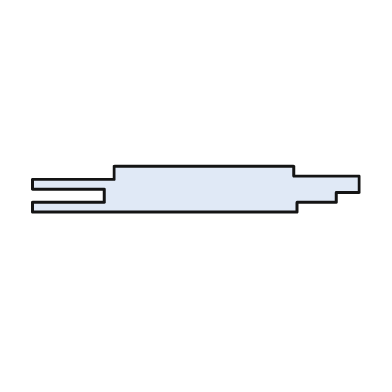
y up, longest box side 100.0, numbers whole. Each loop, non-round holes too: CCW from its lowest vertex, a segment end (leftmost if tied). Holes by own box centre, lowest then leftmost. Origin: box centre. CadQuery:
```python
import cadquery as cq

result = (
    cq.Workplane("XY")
    .moveTo(-50.0, -7.0)
    .lineTo(31.0, -7.0)
    .lineTo(31.0, -4.0)
    .lineTo(43.0, -4.0)
    .lineTo(43.0, -1.0)
    .lineTo(50.0, -1.0)
    .lineTo(50.0, 4.0)
    .lineTo(30.0, 4.0)
    .lineTo(30.0, 7.0)
    .lineTo(-25.0, 7.0)
    .lineTo(-25.0, 3.0)
    .lineTo(-50.0, 3.0)
    .lineTo(-50.0, 0.0)
    .lineTo(-28.0, 0.0)
    .lineTo(-28.0, -4.0)
    .lineTo(-50.0, -4.0)
    .close()
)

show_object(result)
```